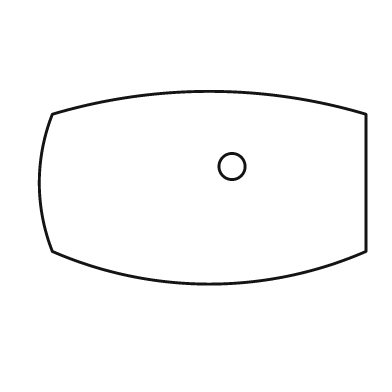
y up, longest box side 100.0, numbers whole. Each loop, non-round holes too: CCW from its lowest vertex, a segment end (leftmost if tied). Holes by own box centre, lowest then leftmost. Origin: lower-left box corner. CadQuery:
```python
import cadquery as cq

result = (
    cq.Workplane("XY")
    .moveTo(4.0, 10.0)
    .threePointArc((52.0, 0.0), (100.0, 10.0))
    .lineTo(100.0, 52.0)
    .threePointArc((52.0, 59.0), (4.0, 52.0))
    .threePointArc((0.0, 31.0), (4.0, 10.0))
    .close()
    .moveTo(59.0, 36.0)
    .circle(4.0)
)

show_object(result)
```